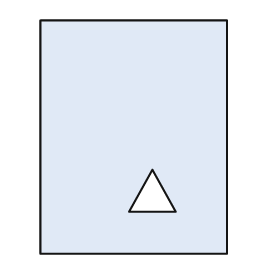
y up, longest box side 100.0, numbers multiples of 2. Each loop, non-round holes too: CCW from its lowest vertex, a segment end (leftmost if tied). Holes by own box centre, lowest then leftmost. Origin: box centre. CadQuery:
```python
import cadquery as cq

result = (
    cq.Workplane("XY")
    .moveTo(-40.0, -50.0)
    .lineTo(40.0, -50.0)
    .lineTo(40.0, 50.0)
    .lineTo(-40.0, 50.0)
    .close()
    .moveTo(-2.0, -32.0)
    .lineTo(18.0, -32.0)
    .lineTo(8.0, -14.0)
    .close()
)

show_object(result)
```